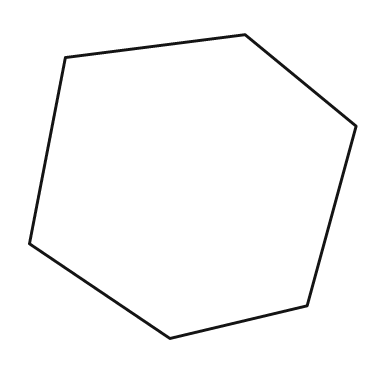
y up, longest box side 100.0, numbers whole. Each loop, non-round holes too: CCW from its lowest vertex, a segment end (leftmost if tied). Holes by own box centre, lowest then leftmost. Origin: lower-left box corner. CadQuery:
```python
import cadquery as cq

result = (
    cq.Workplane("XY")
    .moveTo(43.0, 0.0)
    .lineTo(85.0, 10.0)
    .lineTo(100.0, 65.0)
    .lineTo(66.0, 93.0)
    .lineTo(11.0, 86.0)
    .lineTo(0.0, 29.0)
    .close()
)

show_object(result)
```